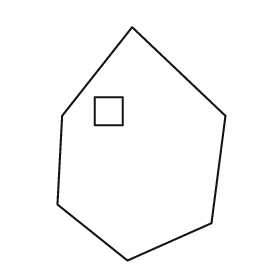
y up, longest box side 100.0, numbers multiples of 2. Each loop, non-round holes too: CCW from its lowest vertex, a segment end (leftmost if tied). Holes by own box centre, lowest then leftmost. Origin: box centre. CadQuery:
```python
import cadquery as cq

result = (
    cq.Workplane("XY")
    .moveTo(-6.0, -50.0)
    .lineTo(30.0, -34.0)
    .lineTo(36.0, 12.0)
    .lineTo(-4.0, 50.0)
    .lineTo(-34.0, 12.0)
    .lineTo(-36.0, -26.0)
    .close()
    .moveTo(-20.0, 8.0)
    .lineTo(-8.0, 8.0)
    .lineTo(-8.0, 20.0)
    .lineTo(-20.0, 20.0)
    .close()
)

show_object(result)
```